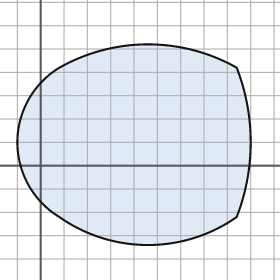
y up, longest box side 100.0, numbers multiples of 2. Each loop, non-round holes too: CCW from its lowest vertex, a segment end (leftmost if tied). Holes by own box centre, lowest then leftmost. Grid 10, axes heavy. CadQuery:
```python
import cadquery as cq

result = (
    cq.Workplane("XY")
    .moveTo(8.0, -22.0)
    .threePointArc((46.0, -34.0), (84.0, -22.0))
    .threePointArc((90.0, 10.0), (84.0, 42.0))
    .threePointArc((46.0, 52.0), (8.0, 42.0))
    .threePointArc((-10.0, 10.0), (8.0, -22.0))
    .close()
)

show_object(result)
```